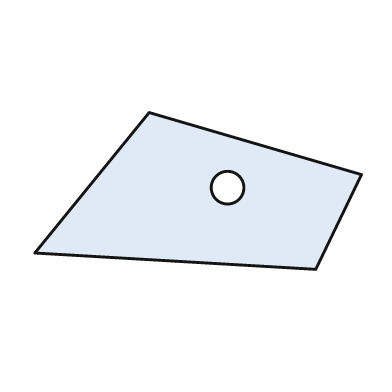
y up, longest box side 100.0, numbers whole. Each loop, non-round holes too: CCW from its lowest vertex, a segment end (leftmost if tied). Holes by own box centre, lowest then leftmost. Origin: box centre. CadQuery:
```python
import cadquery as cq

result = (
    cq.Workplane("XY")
    .moveTo(36.0, -24.0)
    .lineTo(50.0, 5.0)
    .lineTo(-15.0, 24.0)
    .lineTo(-50.0, -19.0)
    .close()
    .moveTo(9.0, 1.0)
    .circle(5.0)
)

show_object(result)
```